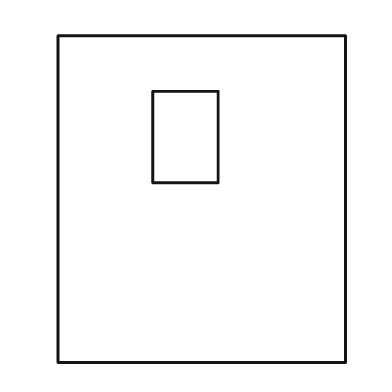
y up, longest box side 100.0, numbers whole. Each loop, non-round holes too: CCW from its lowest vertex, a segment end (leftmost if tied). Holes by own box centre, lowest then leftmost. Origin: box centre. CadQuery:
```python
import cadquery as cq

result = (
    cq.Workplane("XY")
    .moveTo(-44.0, -50.0)
    .lineTo(44.0, -50.0)
    .lineTo(44.0, 50.0)
    .lineTo(-44.0, 50.0)
    .close()
    .moveTo(-15.0, 5.0)
    .lineTo(5.0, 5.0)
    .lineTo(5.0, 33.0)
    .lineTo(-15.0, 33.0)
    .close()
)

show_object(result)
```